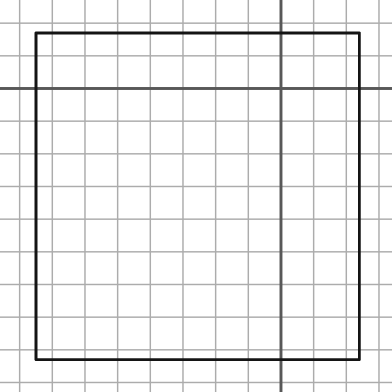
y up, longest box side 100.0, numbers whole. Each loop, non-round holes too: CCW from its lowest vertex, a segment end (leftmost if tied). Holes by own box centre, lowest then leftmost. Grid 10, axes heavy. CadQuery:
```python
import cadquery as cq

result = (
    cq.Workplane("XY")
    .moveTo(-75.0, -83.0)
    .lineTo(24.0, -83.0)
    .lineTo(24.0, 17.0)
    .lineTo(-75.0, 17.0)
    .close()
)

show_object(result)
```